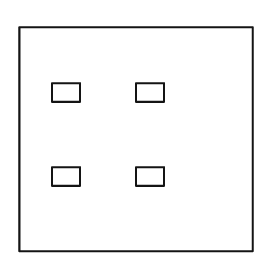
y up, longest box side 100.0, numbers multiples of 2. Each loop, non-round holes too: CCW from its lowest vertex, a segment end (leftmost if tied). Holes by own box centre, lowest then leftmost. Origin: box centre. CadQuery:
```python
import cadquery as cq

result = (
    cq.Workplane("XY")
    .moveTo(-50.0, -48.0)
    .lineTo(50.0, -48.0)
    .lineTo(50.0, 48.0)
    .lineTo(-50.0, 48.0)
    .close()
    .moveTo(-36.0, -20.0)
    .lineTo(-24.0, -20.0)
    .lineTo(-24.0, -12.0)
    .lineTo(-36.0, -12.0)
    .close()
    .moveTo(0.0, -20.0)
    .lineTo(12.0, -20.0)
    .lineTo(12.0, -12.0)
    .lineTo(0.0, -12.0)
    .close()
    .moveTo(-36.0, 16.0)
    .lineTo(-24.0, 16.0)
    .lineTo(-24.0, 24.0)
    .lineTo(-36.0, 24.0)
    .close()
    .moveTo(0.0, 16.0)
    .lineTo(12.0, 16.0)
    .lineTo(12.0, 24.0)
    .lineTo(0.0, 24.0)
    .close()
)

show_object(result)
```